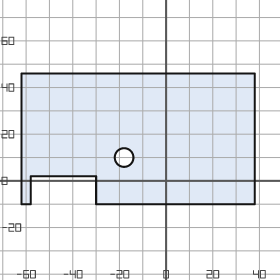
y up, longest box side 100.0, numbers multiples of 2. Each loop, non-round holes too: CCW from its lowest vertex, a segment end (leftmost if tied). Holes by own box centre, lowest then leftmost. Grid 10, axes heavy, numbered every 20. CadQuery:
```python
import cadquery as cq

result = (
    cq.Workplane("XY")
    .moveTo(-62.0, -10.0)
    .lineTo(-58.0, -10.0)
    .lineTo(-58.0, 2.0)
    .lineTo(-30.0, 2.0)
    .lineTo(-30.0, -10.0)
    .lineTo(38.0, -10.0)
    .lineTo(38.0, 46.0)
    .lineTo(-62.0, 46.0)
    .close()
    .moveTo(-18.0, 10.0)
    .circle(4.0)
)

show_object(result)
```